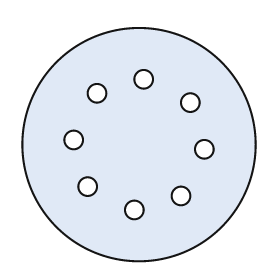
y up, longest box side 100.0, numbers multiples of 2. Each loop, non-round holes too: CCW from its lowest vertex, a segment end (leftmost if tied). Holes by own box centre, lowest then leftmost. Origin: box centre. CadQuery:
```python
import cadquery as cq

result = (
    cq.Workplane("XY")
    .moveTo(0.0, 0.0)
    .circle(50.0)
    .moveTo(-2.0, -28.0)
    .circle(4.0)
    .moveTo(18.0, -22.0)
    .circle(4.0)
    .moveTo(-22.0, -18.0)
    .circle(4.0)
    .moveTo(28.0, -2.0)
    .circle(4.0)
    .moveTo(-28.0, 2.0)
    .circle(4.0)
    .moveTo(22.0, 18.0)
    .circle(4.0)
    .moveTo(-18.0, 22.0)
    .circle(4.0)
    .moveTo(2.0, 28.0)
    .circle(4.0)
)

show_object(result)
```